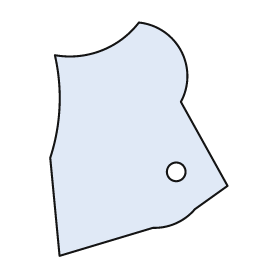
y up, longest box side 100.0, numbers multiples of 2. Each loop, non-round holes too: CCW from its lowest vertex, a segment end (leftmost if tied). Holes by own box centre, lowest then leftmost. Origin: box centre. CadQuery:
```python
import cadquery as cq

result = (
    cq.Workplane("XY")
    .moveTo(-34.0, -50.0)
    .lineTo(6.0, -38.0)
    .threePointArc((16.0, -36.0), (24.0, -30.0))
    .lineTo(38.0, -20.0)
    .lineTo(18.0, 16.0)
    .threePointArc((18.0, 38.0), (0.0, 50.0))
    .threePointArc((-16.0, 38.0), (-36.0, 36.0))
    .threePointArc((-34.0, 14.0), (-38.0, -8.0))
    .close()
    .moveTo(16.0, -14.0)
    .circle(4.0)
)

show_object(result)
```